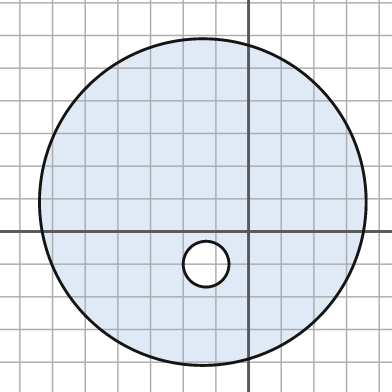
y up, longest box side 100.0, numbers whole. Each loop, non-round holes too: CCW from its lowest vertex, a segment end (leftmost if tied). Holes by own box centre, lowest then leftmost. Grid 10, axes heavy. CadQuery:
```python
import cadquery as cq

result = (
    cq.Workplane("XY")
    .moveTo(-14.0, 9.0)
    .circle(50.0)
    .moveTo(-13.0, -10.0)
    .circle(7.0)
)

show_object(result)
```